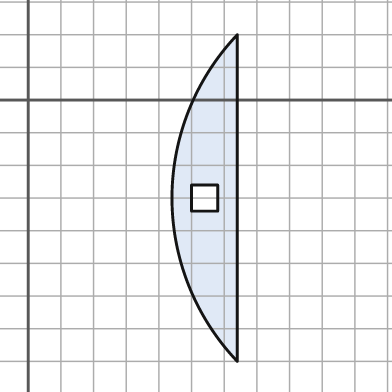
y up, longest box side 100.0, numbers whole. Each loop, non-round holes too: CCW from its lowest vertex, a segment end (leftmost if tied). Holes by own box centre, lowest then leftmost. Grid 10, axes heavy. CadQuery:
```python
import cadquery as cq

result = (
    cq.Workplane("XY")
    .moveTo(64.0, -80.0)
    .lineTo(64.0, 20.0)
    .threePointArc((44.0, -30.0), (64.0, -80.0))
    .close()
    .moveTo(50.0, -34.0)
    .lineTo(58.0, -34.0)
    .lineTo(58.0, -26.0)
    .lineTo(50.0, -26.0)
    .close()
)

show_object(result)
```